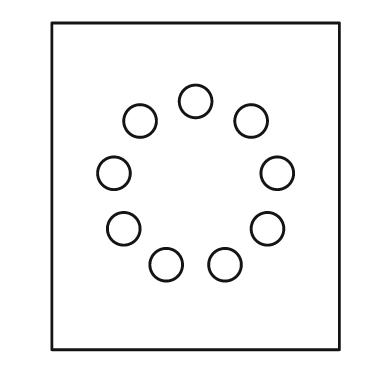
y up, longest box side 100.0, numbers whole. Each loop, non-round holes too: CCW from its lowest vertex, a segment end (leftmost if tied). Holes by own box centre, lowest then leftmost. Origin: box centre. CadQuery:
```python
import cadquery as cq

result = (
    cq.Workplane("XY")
    .moveTo(-44.0, -50.0)
    .lineTo(44.0, -50.0)
    .lineTo(44.0, 50.0)
    .lineTo(-44.0, 50.0)
    .close()
    .moveTo(-9.0, -24.0)
    .circle(5.0)
    .moveTo(9.0, -24.0)
    .circle(5.0)
    .moveTo(-22.0, -13.0)
    .circle(5.0)
    .moveTo(22.0, -13.0)
    .circle(5.0)
    .moveTo(-25.0, 4.0)
    .circle(5.0)
    .moveTo(25.0, 4.0)
    .circle(5.0)
    .moveTo(-17.0, 20.0)
    .circle(5.0)
    .moveTo(17.0, 20.0)
    .circle(5.0)
    .moveTo(0.0, 26.0)
    .circle(5.0)
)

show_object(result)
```